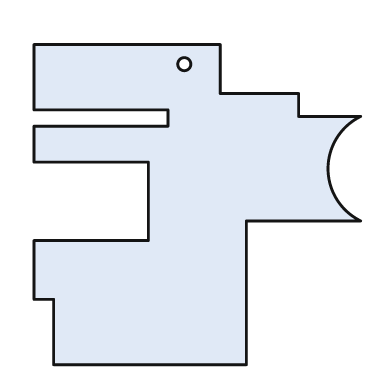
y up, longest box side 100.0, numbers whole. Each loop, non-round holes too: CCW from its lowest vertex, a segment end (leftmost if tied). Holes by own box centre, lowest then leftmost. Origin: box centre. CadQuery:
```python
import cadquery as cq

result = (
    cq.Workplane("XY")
    .moveTo(-44.0, -49.0)
    .lineTo(15.0, -49.0)
    .lineTo(15.0, -5.0)
    .lineTo(50.0, -5.0)
    .threePointArc((40.0, 11.0), (50.0, 27.0))
    .lineTo(31.0, 27.0)
    .lineTo(31.0, 34.0)
    .lineTo(7.0, 34.0)
    .lineTo(7.0, 49.0)
    .lineTo(-50.0, 49.0)
    .lineTo(-50.0, 29.0)
    .lineTo(-9.0, 29.0)
    .lineTo(-9.0, 24.0)
    .lineTo(-50.0, 24.0)
    .lineTo(-50.0, 13.0)
    .lineTo(-15.0, 13.0)
    .lineTo(-15.0, -11.0)
    .lineTo(-50.0, -11.0)
    .lineTo(-50.0, -29.0)
    .lineTo(-44.0, -29.0)
    .close()
    .moveTo(-4.0, 43.0)
    .circle(2.0)
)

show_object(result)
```